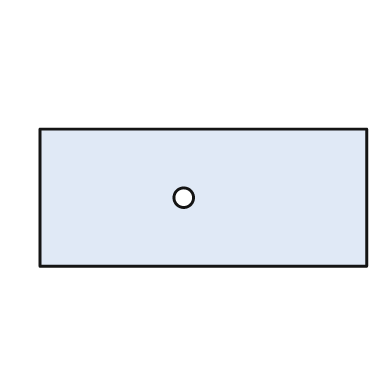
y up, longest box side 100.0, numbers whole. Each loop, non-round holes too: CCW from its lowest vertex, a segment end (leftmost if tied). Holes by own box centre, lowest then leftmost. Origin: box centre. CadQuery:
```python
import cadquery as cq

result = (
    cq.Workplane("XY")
    .moveTo(-50.0, -21.0)
    .lineTo(50.0, -21.0)
    .lineTo(50.0, 21.0)
    .lineTo(-50.0, 21.0)
    .close()
    .moveTo(-6.0, 0.0)
    .circle(3.0)
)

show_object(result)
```